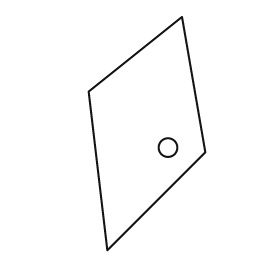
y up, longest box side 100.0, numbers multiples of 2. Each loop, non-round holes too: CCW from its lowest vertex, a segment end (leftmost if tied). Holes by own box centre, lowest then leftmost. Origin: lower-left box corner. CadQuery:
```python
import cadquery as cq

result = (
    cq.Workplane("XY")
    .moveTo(8.0, 0.0)
    .lineTo(50.0, 42.0)
    .lineTo(40.0, 100.0)
    .lineTo(0.0, 68.0)
    .close()
    .moveTo(34.0, 44.0)
    .circle(4.0)
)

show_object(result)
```